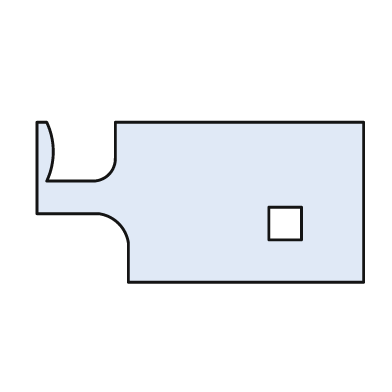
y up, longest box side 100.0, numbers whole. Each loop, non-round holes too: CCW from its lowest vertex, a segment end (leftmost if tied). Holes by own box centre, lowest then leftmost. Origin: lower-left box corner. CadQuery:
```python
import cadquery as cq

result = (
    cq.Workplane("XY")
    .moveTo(28.0, 0.0)
    .lineTo(100.0, 0.0)
    .lineTo(100.0, 49.0)
    .lineTo(24.0, 49.0)
    .lineTo(24.0, 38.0)
    .threePointArc((22.0, 33.0), (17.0, 31.0))
    .lineTo(3.0, 31.0)
    .threePointArc((5.0, 40.0), (3.0, 49.0))
    .lineTo(0.0, 49.0)
    .lineTo(0.0, 21.0)
    .lineTo(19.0, 21.0)
    .threePointArc((25.0, 18.0), (28.0, 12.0))
    .close()
    .moveTo(71.0, 13.0)
    .lineTo(81.0, 13.0)
    .lineTo(81.0, 23.0)
    .lineTo(71.0, 23.0)
    .close()
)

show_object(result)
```